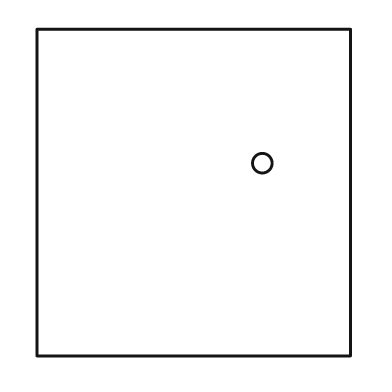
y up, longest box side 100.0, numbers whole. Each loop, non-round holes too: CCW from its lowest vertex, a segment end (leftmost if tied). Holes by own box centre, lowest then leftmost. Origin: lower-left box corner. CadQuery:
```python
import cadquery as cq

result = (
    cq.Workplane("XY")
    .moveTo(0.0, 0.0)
    .lineTo(96.0, 0.0)
    .lineTo(96.0, 100.0)
    .lineTo(0.0, 100.0)
    .close()
    .moveTo(69.0, 59.0)
    .circle(3.0)
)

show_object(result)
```